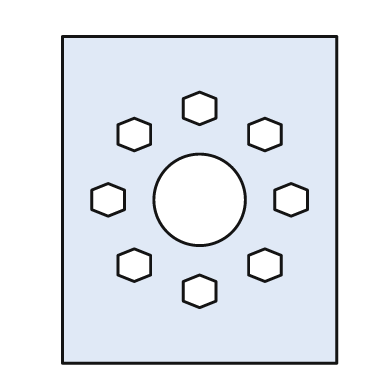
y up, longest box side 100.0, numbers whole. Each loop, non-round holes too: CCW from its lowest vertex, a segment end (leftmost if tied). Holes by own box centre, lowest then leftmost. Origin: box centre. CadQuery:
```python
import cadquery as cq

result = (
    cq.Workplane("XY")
    .moveTo(-42.0, -50.0)
    .lineTo(42.0, -50.0)
    .lineTo(42.0, 50.0)
    .lineTo(-42.0, 50.0)
    .close()
    .moveTo(0.0, -33.0)
    .lineTo(5.0, -31.0)
    .lineTo(5.0, -25.0)
    .lineTo(0.0, -23.0)
    .lineTo(-5.0, -25.0)
    .lineTo(-5.0, -31.0)
    .close()
    .moveTo(-20.0, -25.0)
    .lineTo(-15.0, -23.0)
    .lineTo(-15.0, -17.0)
    .lineTo(-20.0, -15.0)
    .lineTo(-25.0, -17.0)
    .lineTo(-25.0, -23.0)
    .close()
    .moveTo(20.0, -25.0)
    .lineTo(25.0, -23.0)
    .lineTo(25.0, -17.0)
    .lineTo(20.0, -15.0)
    .lineTo(15.0, -17.0)
    .lineTo(15.0, -23.0)
    .close()
    .moveTo(-28.0, -5.0)
    .lineTo(-23.0, -3.0)
    .lineTo(-23.0, 3.0)
    .lineTo(-28.0, 5.0)
    .lineTo(-33.0, 3.0)
    .lineTo(-33.0, -3.0)
    .close()
    .moveTo(0.0, 0.0)
    .circle(14.0)
    .moveTo(28.0, -5.0)
    .lineTo(33.0, -3.0)
    .lineTo(33.0, 3.0)
    .lineTo(28.0, 5.0)
    .lineTo(23.0, 3.0)
    .lineTo(23.0, -3.0)
    .close()
    .moveTo(-20.0, 15.0)
    .lineTo(-15.0, 17.0)
    .lineTo(-15.0, 23.0)
    .lineTo(-20.0, 25.0)
    .lineTo(-25.0, 23.0)
    .lineTo(-25.0, 17.0)
    .close()
    .moveTo(20.0, 15.0)
    .lineTo(25.0, 17.0)
    .lineTo(25.0, 23.0)
    .lineTo(20.0, 25.0)
    .lineTo(15.0, 23.0)
    .lineTo(15.0, 17.0)
    .close()
    .moveTo(0.0, 23.0)
    .lineTo(5.0, 25.0)
    .lineTo(5.0, 31.0)
    .lineTo(0.0, 33.0)
    .lineTo(-5.0, 31.0)
    .lineTo(-5.0, 25.0)
    .close()
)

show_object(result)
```